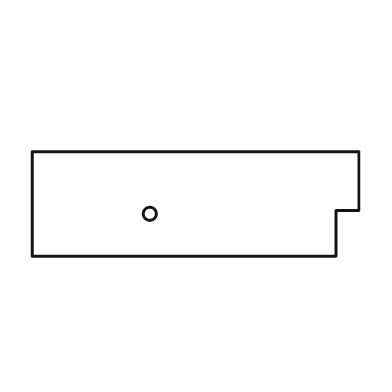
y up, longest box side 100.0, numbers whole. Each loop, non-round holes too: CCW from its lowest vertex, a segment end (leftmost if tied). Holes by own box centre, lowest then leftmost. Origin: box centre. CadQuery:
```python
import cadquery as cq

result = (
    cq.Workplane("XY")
    .moveTo(-50.0, -16.0)
    .lineTo(43.0, -16.0)
    .lineTo(43.0, -2.0)
    .lineTo(50.0, -2.0)
    .lineTo(50.0, 16.0)
    .lineTo(-50.0, 16.0)
    .close()
    .moveTo(-14.0, -3.0)
    .circle(2.0)
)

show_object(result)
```